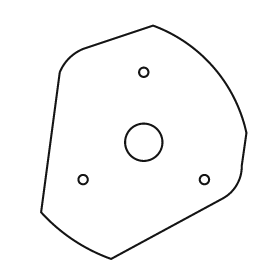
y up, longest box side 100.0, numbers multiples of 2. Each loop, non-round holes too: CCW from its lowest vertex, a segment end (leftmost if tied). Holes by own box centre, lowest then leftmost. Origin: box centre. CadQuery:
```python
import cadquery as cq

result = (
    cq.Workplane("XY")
    .moveTo(-14.0, -50.0)
    .lineTo(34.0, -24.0)
    .threePointArc((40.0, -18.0), (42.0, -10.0))
    .lineTo(44.0, 4.0)
    .threePointArc((30.0, 32.0), (4.0, 50.0))
    .lineTo(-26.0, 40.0)
    .threePointArc((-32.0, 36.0), (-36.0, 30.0))
    .lineTo(-44.0, -30.0)
    .threePointArc((-30.0, -42.0), (-14.0, -50.0))
    .close()
    .moveTo(-26.0, -16.0)
    .circle(2.0)
    .moveTo(26.0, -16.0)
    .circle(2.0)
    .moveTo(0.0, 0.0)
    .circle(8.0)
    .moveTo(0.0, 30.0)
    .circle(2.0)
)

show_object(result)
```